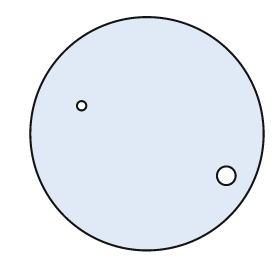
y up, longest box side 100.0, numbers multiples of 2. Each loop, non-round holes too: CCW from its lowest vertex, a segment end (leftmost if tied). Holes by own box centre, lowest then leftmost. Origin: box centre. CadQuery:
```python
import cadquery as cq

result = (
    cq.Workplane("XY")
    .moveTo(0.0, 0.0)
    .circle(50.0)
    .moveTo(34.0, -18.0)
    .circle(4.0)
    .moveTo(-28.0, 12.0)
    .circle(2.0)
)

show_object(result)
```